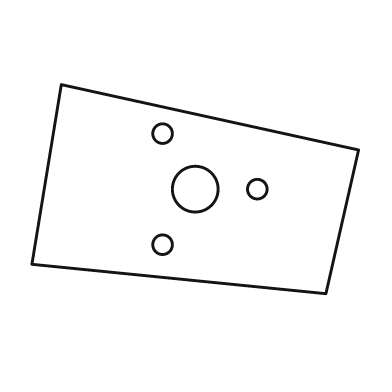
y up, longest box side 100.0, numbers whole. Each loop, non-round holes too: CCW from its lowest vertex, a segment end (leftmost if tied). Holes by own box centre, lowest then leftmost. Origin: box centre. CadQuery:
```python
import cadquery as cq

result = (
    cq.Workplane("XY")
    .moveTo(40.0, -32.0)
    .lineTo(50.0, 12.0)
    .lineTo(-41.0, 32.0)
    .lineTo(-50.0, -23.0)
    .close()
    .moveTo(-10.0, -17.0)
    .circle(3.0)
    .moveTo(0.0, 0.0)
    .circle(7.0)
    .moveTo(19.0, 0.0)
    .circle(3.0)
    .moveTo(-10.0, 17.0)
    .circle(3.0)
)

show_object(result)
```